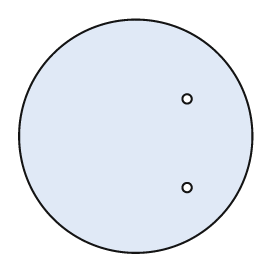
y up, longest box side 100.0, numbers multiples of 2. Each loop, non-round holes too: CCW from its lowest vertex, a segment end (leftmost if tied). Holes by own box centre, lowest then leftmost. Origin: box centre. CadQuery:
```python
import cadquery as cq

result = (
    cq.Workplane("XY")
    .moveTo(0.0, 0.0)
    .circle(50.0)
    .moveTo(22.0, -22.0)
    .circle(2.0)
    .moveTo(22.0, 16.0)
    .circle(2.0)
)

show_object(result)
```